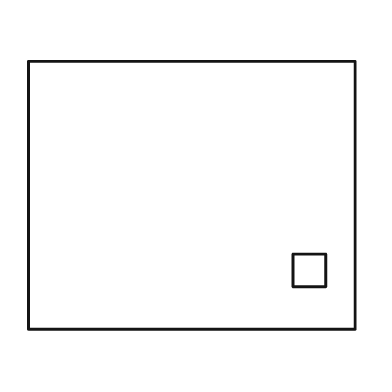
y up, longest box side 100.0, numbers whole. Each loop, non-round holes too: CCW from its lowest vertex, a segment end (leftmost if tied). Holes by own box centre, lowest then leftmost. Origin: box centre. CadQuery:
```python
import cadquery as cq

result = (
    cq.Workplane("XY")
    .moveTo(-50.0, -41.0)
    .lineTo(50.0, -41.0)
    .lineTo(50.0, 41.0)
    .lineTo(-50.0, 41.0)
    .close()
    .moveTo(31.0, -28.0)
    .lineTo(41.0, -28.0)
    .lineTo(41.0, -18.0)
    .lineTo(31.0, -18.0)
    .close()
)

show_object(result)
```